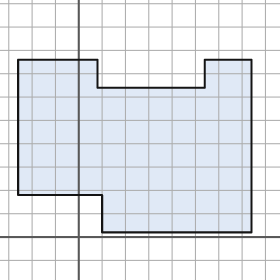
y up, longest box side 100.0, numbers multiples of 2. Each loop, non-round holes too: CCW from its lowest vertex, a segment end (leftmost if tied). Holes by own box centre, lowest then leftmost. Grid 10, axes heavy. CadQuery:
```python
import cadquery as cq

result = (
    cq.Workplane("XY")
    .moveTo(10.0, 2.0)
    .lineTo(74.0, 2.0)
    .lineTo(74.0, 76.0)
    .lineTo(54.0, 76.0)
    .lineTo(54.0, 64.0)
    .lineTo(8.0, 64.0)
    .lineTo(8.0, 76.0)
    .lineTo(-26.0, 76.0)
    .lineTo(-26.0, 18.0)
    .lineTo(10.0, 18.0)
    .close()
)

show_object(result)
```